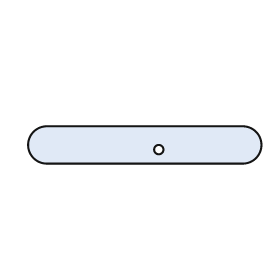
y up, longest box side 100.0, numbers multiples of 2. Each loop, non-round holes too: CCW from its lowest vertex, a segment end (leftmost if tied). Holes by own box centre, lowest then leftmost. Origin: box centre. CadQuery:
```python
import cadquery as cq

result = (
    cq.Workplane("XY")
    .moveTo(-42.0, -8.0)
    .lineTo(42.0, -8.0)
    .threePointArc((50.0, 0.0), (42.0, 8.0))
    .lineTo(-42.0, 8.0)
    .threePointArc((-50.0, 0.0), (-42.0, -8.0))
    .close()
    .moveTo(6.0, -2.0)
    .circle(2.0)
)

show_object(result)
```